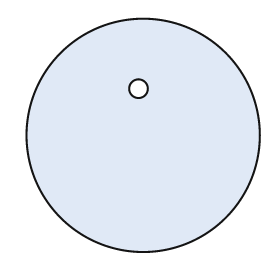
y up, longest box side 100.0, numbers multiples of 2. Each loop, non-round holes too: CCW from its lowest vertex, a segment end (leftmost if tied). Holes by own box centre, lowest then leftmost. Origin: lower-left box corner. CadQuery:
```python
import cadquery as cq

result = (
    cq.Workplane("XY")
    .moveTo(50.0, 50.0)
    .circle(50.0)
    .moveTo(48.0, 70.0)
    .circle(4.0)
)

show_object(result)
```